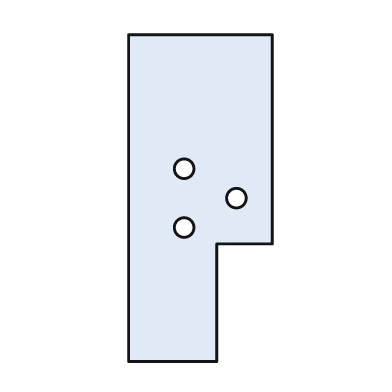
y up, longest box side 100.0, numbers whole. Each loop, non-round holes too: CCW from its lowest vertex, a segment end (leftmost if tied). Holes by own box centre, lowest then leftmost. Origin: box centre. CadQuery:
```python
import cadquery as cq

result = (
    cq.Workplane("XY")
    .moveTo(-22.0, -50.0)
    .lineTo(5.0, -50.0)
    .lineTo(5.0, -14.0)
    .lineTo(22.0, -14.0)
    .lineTo(22.0, 50.0)
    .lineTo(-22.0, 50.0)
    .close()
    .moveTo(-5.0, -9.0)
    .circle(3.0)
    .moveTo(11.0, 0.0)
    .circle(3.0)
    .moveTo(-5.0, 9.0)
    .circle(3.0)
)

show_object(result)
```